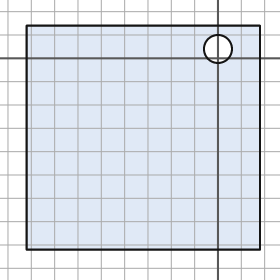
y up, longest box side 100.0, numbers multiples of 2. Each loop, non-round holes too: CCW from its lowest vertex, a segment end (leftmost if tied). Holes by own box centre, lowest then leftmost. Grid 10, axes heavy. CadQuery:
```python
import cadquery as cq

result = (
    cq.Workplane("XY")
    .moveTo(-82.0, -82.0)
    .lineTo(18.0, -82.0)
    .lineTo(18.0, 14.0)
    .lineTo(-82.0, 14.0)
    .close()
    .moveTo(0.0, 4.0)
    .circle(6.0)
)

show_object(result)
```